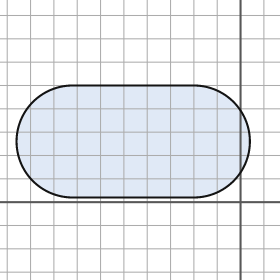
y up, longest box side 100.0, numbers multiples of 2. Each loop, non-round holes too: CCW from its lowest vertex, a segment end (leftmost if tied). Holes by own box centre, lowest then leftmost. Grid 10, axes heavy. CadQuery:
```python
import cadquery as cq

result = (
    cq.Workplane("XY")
    .moveTo(-72.0, 2.0)
    .lineTo(-20.0, 2.0)
    .threePointArc((4.0, 26.0), (-20.0, 50.0))
    .lineTo(-72.0, 50.0)
    .threePointArc((-96.0, 26.0), (-72.0, 2.0))
    .close()
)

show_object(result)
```